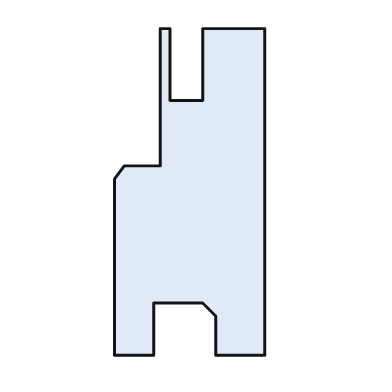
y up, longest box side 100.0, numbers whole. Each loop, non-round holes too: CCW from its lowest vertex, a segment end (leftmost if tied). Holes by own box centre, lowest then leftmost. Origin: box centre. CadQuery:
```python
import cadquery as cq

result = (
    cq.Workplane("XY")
    .moveTo(-23.0, -50.0)
    .lineTo(-11.0, -50.0)
    .lineTo(-11.0, -34.0)
    .lineTo(4.0, -34.0)
    .lineTo(8.0, -38.0)
    .lineTo(8.0, -50.0)
    .lineTo(23.0, -50.0)
    .lineTo(23.0, 50.0)
    .lineTo(4.0, 50.0)
    .lineTo(4.0, 28.0)
    .lineTo(-6.0, 28.0)
    .lineTo(-6.0, 50.0)
    .lineTo(-9.0, 50.0)
    .lineTo(-9.0, 8.0)
    .lineTo(-20.0, 8.0)
    .lineTo(-23.0, 4.0)
    .close()
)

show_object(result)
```